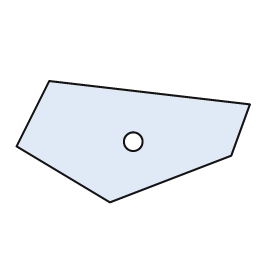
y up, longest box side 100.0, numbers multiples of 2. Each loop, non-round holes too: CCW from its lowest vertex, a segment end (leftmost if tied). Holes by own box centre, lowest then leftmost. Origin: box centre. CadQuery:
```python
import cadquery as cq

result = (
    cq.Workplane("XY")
    .moveTo(-10.0, -26.0)
    .lineTo(42.0, -6.0)
    .lineTo(50.0, 16.0)
    .lineTo(-36.0, 26.0)
    .lineTo(-50.0, -2.0)
    .close()
    .moveTo(0.0, 0.0)
    .circle(4.0)
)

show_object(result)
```